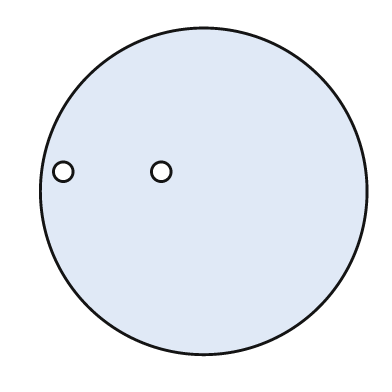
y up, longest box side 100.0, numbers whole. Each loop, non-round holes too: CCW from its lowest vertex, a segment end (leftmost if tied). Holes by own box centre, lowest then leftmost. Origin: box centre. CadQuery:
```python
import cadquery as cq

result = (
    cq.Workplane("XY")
    .moveTo(0.0, 0.0)
    .circle(50.0)
    .moveTo(-43.0, 6.0)
    .circle(3.0)
    .moveTo(-13.0, 6.0)
    .circle(3.0)
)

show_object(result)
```